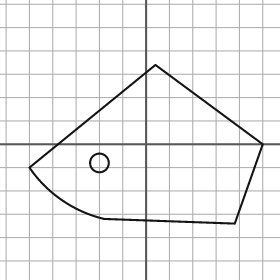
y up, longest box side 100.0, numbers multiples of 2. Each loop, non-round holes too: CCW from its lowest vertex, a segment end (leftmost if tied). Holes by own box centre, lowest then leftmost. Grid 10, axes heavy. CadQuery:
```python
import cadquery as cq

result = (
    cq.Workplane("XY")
    .moveTo(38.0, -34.0)
    .lineTo(50.0, 0.0)
    .lineTo(4.0, 34.0)
    .lineTo(-50.0, -10.0)
    .threePointArc((-36.0, -24.0), (-18.0, -32.0))
    .close()
    .moveTo(-20.0, -8.0)
    .circle(4.0)
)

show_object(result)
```